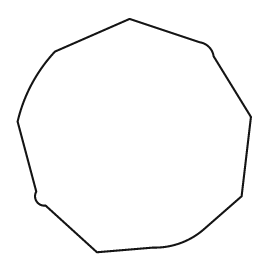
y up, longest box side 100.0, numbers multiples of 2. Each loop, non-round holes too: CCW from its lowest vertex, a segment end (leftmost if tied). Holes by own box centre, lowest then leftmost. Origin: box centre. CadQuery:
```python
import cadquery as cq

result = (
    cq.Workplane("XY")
    .moveTo(-16.0, -50.0)
    .lineTo(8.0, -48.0)
    .threePointArc((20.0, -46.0), (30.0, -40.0))
    .lineTo(46.0, -26.0)
    .lineTo(50.0, 8.0)
    .lineTo(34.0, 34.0)
    .threePointArc((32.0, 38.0), (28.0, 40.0))
    .lineTo(-2.0, 50.0)
    .lineTo(-34.0, 36.0)
    .threePointArc((-44.0, 22.0), (-50.0, 6.0))
    .lineTo(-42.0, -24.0)
    .threePointArc((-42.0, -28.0), (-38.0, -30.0))
    .close()
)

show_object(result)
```